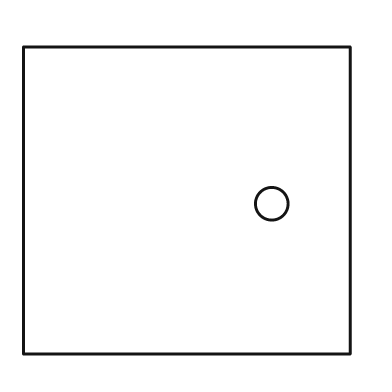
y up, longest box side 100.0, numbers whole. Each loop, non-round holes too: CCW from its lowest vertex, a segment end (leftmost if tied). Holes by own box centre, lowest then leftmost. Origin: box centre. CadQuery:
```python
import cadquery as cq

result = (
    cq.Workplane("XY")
    .moveTo(-50.0, -47.0)
    .lineTo(50.0, -47.0)
    .lineTo(50.0, 47.0)
    .lineTo(-50.0, 47.0)
    .close()
    .moveTo(26.0, -1.0)
    .circle(5.0)
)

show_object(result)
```